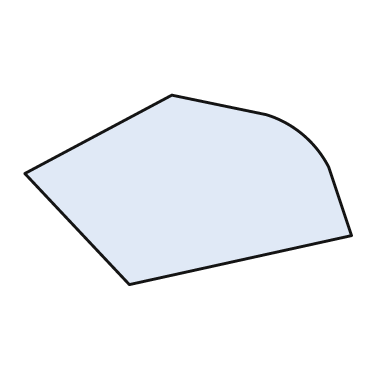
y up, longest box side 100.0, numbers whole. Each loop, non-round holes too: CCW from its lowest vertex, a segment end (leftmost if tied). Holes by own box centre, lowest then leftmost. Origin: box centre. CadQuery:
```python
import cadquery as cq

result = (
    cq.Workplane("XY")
    .moveTo(-18.0, -29.0)
    .lineTo(50.0, -14.0)
    .lineTo(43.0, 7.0)
    .threePointArc((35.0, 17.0), (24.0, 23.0))
    .lineTo(-5.0, 29.0)
    .lineTo(-50.0, 5.0)
    .close()
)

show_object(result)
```